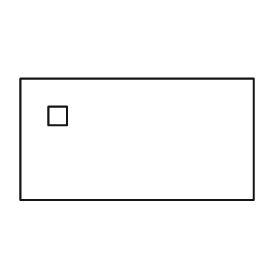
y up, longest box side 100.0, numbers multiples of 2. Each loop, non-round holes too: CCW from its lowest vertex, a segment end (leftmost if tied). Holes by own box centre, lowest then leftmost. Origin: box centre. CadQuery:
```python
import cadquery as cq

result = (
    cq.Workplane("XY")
    .moveTo(-50.0, -26.0)
    .lineTo(50.0, -26.0)
    .lineTo(50.0, 26.0)
    .lineTo(-50.0, 26.0)
    .close()
    .moveTo(-38.0, 6.0)
    .lineTo(-30.0, 6.0)
    .lineTo(-30.0, 14.0)
    .lineTo(-38.0, 14.0)
    .close()
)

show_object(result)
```